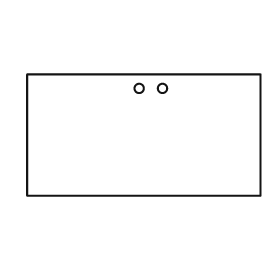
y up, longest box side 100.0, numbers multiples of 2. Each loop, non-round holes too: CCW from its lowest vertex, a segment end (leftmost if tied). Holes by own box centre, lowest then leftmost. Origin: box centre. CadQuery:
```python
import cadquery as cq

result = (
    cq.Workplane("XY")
    .moveTo(-50.0, -26.0)
    .lineTo(50.0, -26.0)
    .lineTo(50.0, 26.0)
    .lineTo(-50.0, 26.0)
    .close()
    .moveTo(-2.0, 20.0)
    .circle(2.0)
    .moveTo(8.0, 20.0)
    .circle(2.0)
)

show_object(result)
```